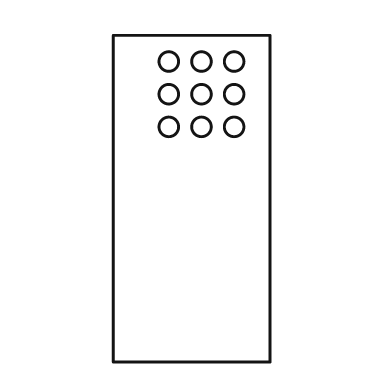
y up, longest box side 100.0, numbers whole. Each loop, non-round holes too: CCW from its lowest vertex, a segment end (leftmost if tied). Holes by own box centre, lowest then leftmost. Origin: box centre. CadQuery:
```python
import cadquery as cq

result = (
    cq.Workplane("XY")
    .moveTo(-24.0, -50.0)
    .lineTo(24.0, -50.0)
    .lineTo(24.0, 50.0)
    .lineTo(-24.0, 50.0)
    .close()
    .moveTo(-7.0, 22.0)
    .circle(3.0)
    .moveTo(3.0, 22.0)
    .circle(3.0)
    .moveTo(13.0, 22.0)
    .circle(3.0)
    .moveTo(-7.0, 32.0)
    .circle(3.0)
    .moveTo(3.0, 32.0)
    .circle(3.0)
    .moveTo(13.0, 32.0)
    .circle(3.0)
    .moveTo(-7.0, 42.0)
    .circle(3.0)
    .moveTo(3.0, 42.0)
    .circle(3.0)
    .moveTo(13.0, 42.0)
    .circle(3.0)
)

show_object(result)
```